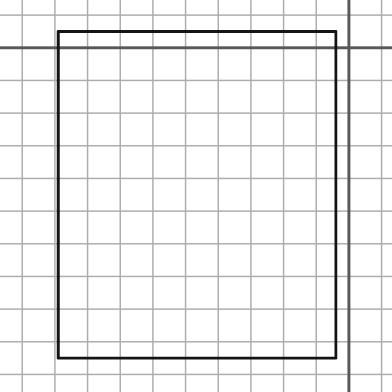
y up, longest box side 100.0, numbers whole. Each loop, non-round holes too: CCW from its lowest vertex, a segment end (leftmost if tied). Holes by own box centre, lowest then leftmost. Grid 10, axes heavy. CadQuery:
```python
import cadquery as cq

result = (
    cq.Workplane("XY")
    .moveTo(-89.0, -95.0)
    .lineTo(-4.0, -95.0)
    .lineTo(-4.0, 5.0)
    .lineTo(-89.0, 5.0)
    .close()
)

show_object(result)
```